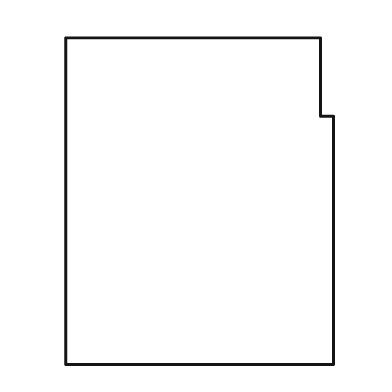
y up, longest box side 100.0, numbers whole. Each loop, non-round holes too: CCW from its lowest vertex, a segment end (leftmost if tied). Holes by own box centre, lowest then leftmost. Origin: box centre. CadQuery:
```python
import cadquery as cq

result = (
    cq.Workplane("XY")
    .moveTo(-41.0, -50.0)
    .lineTo(41.0, -50.0)
    .lineTo(41.0, 26.0)
    .lineTo(37.0, 26.0)
    .lineTo(37.0, 50.0)
    .lineTo(-41.0, 50.0)
    .close()
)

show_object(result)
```